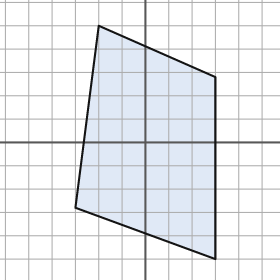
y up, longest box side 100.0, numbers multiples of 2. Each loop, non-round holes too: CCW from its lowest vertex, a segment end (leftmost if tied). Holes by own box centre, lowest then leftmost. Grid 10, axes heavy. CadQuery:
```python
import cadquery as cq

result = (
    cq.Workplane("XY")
    .moveTo(30.0, -50.0)
    .lineTo(30.0, 28.0)
    .lineTo(-20.0, 50.0)
    .lineTo(-30.0, -28.0)
    .close()
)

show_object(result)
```